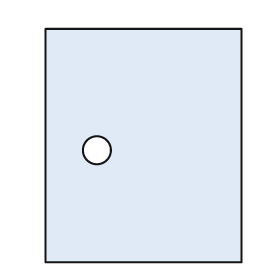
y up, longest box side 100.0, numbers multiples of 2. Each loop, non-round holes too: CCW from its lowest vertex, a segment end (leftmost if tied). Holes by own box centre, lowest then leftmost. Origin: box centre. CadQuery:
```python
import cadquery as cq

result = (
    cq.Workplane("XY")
    .moveTo(-42.0, -50.0)
    .lineTo(42.0, -50.0)
    .lineTo(42.0, 50.0)
    .lineTo(-42.0, 50.0)
    .close()
    .moveTo(-20.0, -2.0)
    .circle(6.0)
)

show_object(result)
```